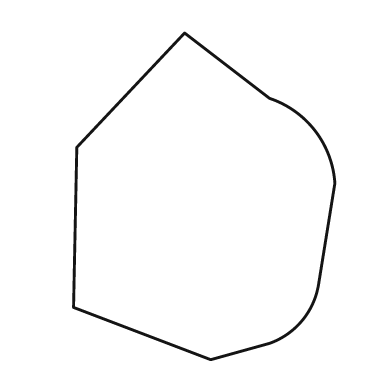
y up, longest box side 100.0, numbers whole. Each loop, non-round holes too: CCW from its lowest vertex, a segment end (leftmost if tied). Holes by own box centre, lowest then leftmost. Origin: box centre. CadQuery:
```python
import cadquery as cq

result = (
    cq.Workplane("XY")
    .moveTo(2.0, -50.0)
    .lineTo(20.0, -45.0)
    .threePointArc((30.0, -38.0), (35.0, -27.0))
    .lineTo(40.0, 4.0)
    .threePointArc((34.0, 20.0), (20.0, 30.0))
    .lineTo(-6.0, 50.0)
    .lineTo(-39.0, 15.0)
    .lineTo(-40.0, -34.0)
    .close()
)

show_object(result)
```